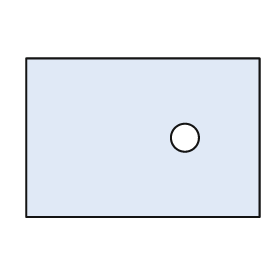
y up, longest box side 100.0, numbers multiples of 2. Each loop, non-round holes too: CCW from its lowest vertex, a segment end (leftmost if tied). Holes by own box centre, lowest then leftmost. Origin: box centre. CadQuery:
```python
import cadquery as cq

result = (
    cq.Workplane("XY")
    .moveTo(-50.0, -34.0)
    .lineTo(50.0, -34.0)
    .lineTo(50.0, 34.0)
    .lineTo(-50.0, 34.0)
    .close()
    .moveTo(18.0, 0.0)
    .circle(6.0)
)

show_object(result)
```